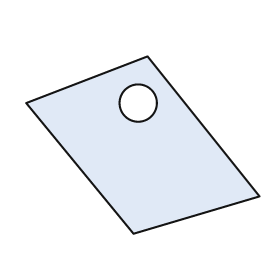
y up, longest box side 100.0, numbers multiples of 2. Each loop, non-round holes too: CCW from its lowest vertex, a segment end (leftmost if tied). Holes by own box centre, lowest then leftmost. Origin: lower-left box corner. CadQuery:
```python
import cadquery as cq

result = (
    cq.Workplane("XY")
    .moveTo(46.0, 0.0)
    .lineTo(100.0, 16.0)
    .lineTo(52.0, 76.0)
    .lineTo(0.0, 56.0)
    .close()
    .moveTo(48.0, 56.0)
    .circle(8.0)
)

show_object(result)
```